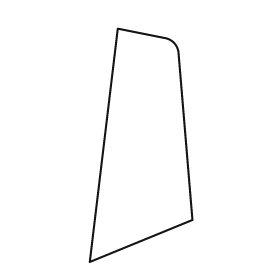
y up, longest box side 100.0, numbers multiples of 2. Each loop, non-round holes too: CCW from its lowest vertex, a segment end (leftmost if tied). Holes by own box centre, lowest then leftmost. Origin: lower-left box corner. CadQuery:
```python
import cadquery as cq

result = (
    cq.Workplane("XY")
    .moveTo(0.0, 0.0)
    .lineTo(44.0, 18.0)
    .lineTo(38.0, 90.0)
    .threePointArc((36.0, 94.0), (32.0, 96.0))
    .lineTo(12.0, 100.0)
    .close()
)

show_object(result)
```